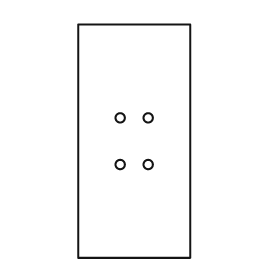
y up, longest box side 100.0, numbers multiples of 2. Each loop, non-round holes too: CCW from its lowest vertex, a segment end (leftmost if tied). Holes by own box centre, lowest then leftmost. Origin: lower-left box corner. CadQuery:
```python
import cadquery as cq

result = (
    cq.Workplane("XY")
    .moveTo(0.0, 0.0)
    .lineTo(48.0, 0.0)
    .lineTo(48.0, 100.0)
    .lineTo(0.0, 100.0)
    .close()
    .moveTo(18.0, 40.0)
    .circle(2.0)
    .moveTo(30.0, 40.0)
    .circle(2.0)
    .moveTo(18.0, 60.0)
    .circle(2.0)
    .moveTo(30.0, 60.0)
    .circle(2.0)
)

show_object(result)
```